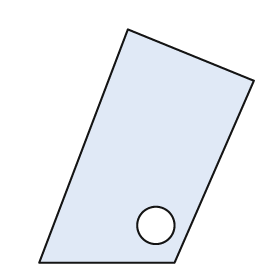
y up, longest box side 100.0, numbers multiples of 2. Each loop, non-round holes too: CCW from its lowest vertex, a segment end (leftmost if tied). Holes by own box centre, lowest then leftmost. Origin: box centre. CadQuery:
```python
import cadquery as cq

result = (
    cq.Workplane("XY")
    .moveTo(-46.0, -50.0)
    .lineTo(12.0, -50.0)
    .lineTo(46.0, 28.0)
    .lineTo(-8.0, 50.0)
    .close()
    .moveTo(4.0, -34.0)
    .circle(8.0)
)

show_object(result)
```